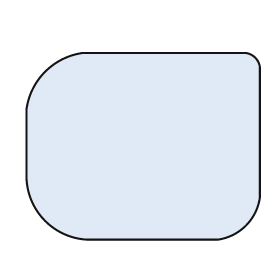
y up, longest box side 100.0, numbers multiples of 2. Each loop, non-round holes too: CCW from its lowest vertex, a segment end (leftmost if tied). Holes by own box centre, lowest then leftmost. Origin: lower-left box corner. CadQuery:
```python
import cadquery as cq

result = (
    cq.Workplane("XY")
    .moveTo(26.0, 0.0)
    .lineTo(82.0, 0.0)
    .threePointArc((94.0, 6.0), (100.0, 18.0))
    .lineTo(100.0, 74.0)
    .threePointArc((98.0, 78.0), (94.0, 80.0))
    .lineTo(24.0, 80.0)
    .threePointArc((8.0, 72.0), (0.0, 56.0))
    .lineTo(0.0, 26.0)
    .threePointArc((8.0, 8.0), (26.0, 0.0))
    .close()
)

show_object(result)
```